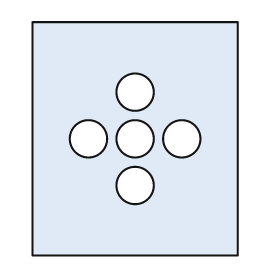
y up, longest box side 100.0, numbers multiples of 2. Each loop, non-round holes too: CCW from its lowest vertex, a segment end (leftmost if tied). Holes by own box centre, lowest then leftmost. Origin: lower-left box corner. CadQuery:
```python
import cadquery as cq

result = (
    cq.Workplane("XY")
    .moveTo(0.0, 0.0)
    .lineTo(88.0, 0.0)
    .lineTo(88.0, 100.0)
    .lineTo(0.0, 100.0)
    .close()
    .moveTo(44.0, 30.0)
    .circle(8.0)
    .moveTo(24.0, 50.0)
    .circle(8.0)
    .moveTo(44.0, 50.0)
    .circle(8.0)
    .moveTo(64.0, 50.0)
    .circle(8.0)
    .moveTo(44.0, 70.0)
    .circle(8.0)
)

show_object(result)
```